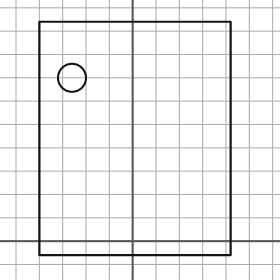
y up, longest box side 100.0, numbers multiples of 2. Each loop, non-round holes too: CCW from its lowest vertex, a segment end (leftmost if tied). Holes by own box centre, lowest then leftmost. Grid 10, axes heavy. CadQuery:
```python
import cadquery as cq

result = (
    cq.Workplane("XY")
    .moveTo(-40.0, -6.0)
    .lineTo(42.0, -6.0)
    .lineTo(42.0, 94.0)
    .lineTo(-40.0, 94.0)
    .close()
    .moveTo(-26.0, 70.0)
    .circle(6.0)
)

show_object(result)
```